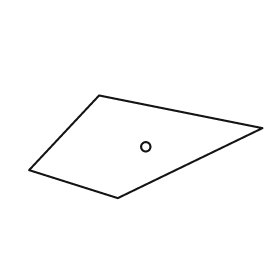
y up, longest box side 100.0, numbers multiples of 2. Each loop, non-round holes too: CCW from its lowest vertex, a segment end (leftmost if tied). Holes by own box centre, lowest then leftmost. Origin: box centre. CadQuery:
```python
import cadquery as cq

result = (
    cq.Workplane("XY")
    .moveTo(-12.0, -22.0)
    .lineTo(50.0, 8.0)
    .lineTo(-20.0, 22.0)
    .lineTo(-50.0, -10.0)
    .close()
    .moveTo(0.0, 0.0)
    .circle(2.0)
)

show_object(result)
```